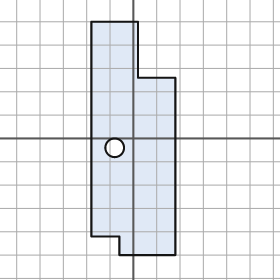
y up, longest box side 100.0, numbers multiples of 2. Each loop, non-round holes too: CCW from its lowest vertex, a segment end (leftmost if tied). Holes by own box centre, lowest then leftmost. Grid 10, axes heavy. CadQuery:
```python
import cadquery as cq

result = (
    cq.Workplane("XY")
    .moveTo(-6.0, -50.0)
    .lineTo(18.0, -50.0)
    .lineTo(18.0, 26.0)
    .lineTo(2.0, 26.0)
    .lineTo(2.0, 50.0)
    .lineTo(-18.0, 50.0)
    .lineTo(-18.0, -42.0)
    .lineTo(-6.0, -42.0)
    .close()
    .moveTo(-8.0, -4.0)
    .circle(4.0)
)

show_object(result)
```